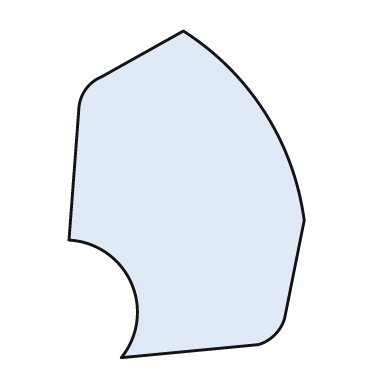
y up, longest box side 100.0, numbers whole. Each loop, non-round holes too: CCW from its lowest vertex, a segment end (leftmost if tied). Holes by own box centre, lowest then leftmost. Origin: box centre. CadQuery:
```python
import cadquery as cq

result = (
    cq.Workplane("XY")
    .moveTo(-20.0, -50.0)
    .lineTo(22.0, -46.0)
    .threePointArc((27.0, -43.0), (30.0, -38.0))
    .lineTo(36.0, -8.0)
    .threePointArc((24.0, 25.0), (-1.0, 50.0))
    .lineTo(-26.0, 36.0)
    .threePointArc((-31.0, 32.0), (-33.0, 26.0))
    .lineTo(-36.0, -14.0)
    .threePointArc((-17.0, -27.0), (-20.0, -50.0))
    .close()
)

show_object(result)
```